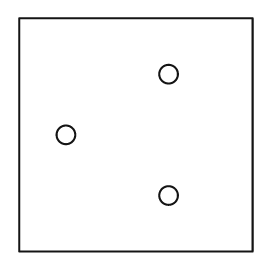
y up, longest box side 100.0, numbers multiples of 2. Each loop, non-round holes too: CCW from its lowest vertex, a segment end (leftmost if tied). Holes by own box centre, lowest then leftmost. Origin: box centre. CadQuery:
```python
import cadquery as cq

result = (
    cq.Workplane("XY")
    .moveTo(-50.0, -50.0)
    .lineTo(50.0, -50.0)
    .lineTo(50.0, 50.0)
    .lineTo(-50.0, 50.0)
    .close()
    .moveTo(14.0, -26.0)
    .circle(4.0)
    .moveTo(-30.0, 0.0)
    .circle(4.0)
    .moveTo(14.0, 26.0)
    .circle(4.0)
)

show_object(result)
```